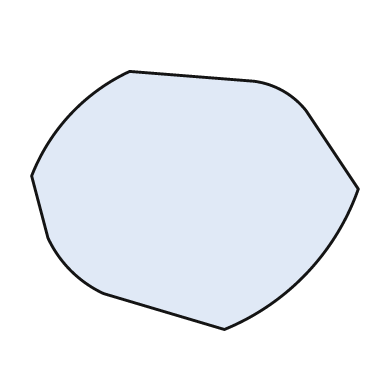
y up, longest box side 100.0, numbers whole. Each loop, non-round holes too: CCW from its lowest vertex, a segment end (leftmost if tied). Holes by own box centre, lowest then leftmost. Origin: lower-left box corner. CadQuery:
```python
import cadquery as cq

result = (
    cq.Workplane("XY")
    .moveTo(59.0, 0.0)
    .threePointArc((84.0, 17.0), (100.0, 43.0))
    .lineTo(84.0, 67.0)
    .threePointArc((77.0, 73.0), (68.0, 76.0))
    .lineTo(30.0, 79.0)
    .threePointArc((12.0, 66.0), (0.0, 47.0))
    .lineTo(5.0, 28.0)
    .threePointArc((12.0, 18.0), (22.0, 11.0))
    .close()
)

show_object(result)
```